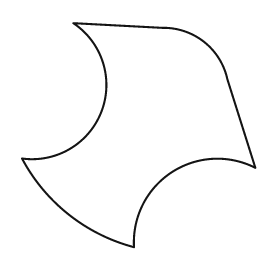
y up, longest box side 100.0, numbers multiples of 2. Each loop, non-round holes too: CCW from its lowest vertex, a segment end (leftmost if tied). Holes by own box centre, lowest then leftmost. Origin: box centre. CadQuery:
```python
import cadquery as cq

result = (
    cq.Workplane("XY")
    .moveTo(-2.0, -48.0)
    .threePointArc((14.0, -16.0), (50.0, -14.0))
    .lineTo(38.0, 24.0)
    .threePointArc((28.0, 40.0), (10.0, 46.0))
    .lineTo(-28.0, 48.0)
    .threePointArc((-16.0, 10.0), (-50.0, -10.0))
    .threePointArc((-30.0, -34.0), (-2.0, -48.0))
    .close()
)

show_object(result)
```